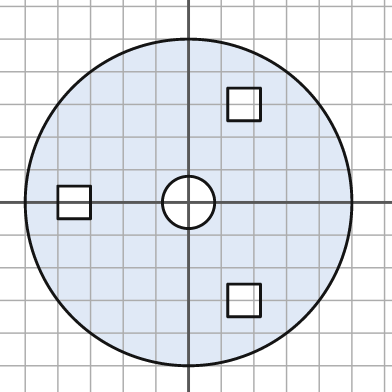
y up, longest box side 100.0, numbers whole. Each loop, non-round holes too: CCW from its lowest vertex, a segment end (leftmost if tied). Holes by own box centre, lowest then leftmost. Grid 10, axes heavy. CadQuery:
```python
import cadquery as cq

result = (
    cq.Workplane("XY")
    .moveTo(0.0, 0.0)
    .circle(50.0)
    .moveTo(12.0, -35.0)
    .lineTo(22.0, -35.0)
    .lineTo(22.0, -25.0)
    .lineTo(12.0, -25.0)
    .close()
    .moveTo(-40.0, -5.0)
    .lineTo(-30.0, -5.0)
    .lineTo(-30.0, 5.0)
    .lineTo(-40.0, 5.0)
    .close()
    .moveTo(0.0, 0.0)
    .circle(8.0)
    .moveTo(12.0, 25.0)
    .lineTo(22.0, 25.0)
    .lineTo(22.0, 35.0)
    .lineTo(12.0, 35.0)
    .close()
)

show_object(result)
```